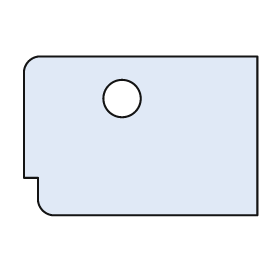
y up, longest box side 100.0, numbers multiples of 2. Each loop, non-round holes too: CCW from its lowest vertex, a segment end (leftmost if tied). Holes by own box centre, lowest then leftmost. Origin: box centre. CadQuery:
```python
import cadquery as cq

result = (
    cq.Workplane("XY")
    .moveTo(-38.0, -34.0)
    .lineTo(50.0, -34.0)
    .lineTo(50.0, 34.0)
    .lineTo(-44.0, 34.0)
    .threePointArc((-48.0, 32.0), (-50.0, 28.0))
    .lineTo(-50.0, -18.0)
    .lineTo(-44.0, -18.0)
    .lineTo(-44.0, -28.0)
    .threePointArc((-42.0, -32.0), (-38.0, -34.0))
    .close()
    .moveTo(-8.0, 16.0)
    .circle(8.0)
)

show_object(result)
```